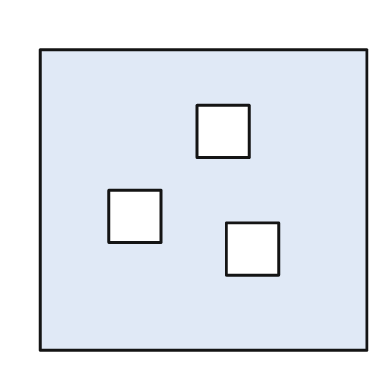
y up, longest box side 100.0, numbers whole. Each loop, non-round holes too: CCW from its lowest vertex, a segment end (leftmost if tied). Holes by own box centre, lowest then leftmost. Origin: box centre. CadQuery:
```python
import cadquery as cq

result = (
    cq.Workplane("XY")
    .moveTo(-50.0, -46.0)
    .lineTo(50.0, -46.0)
    .lineTo(50.0, 46.0)
    .lineTo(-50.0, 46.0)
    .close()
    .moveTo(7.0, -23.0)
    .lineTo(23.0, -23.0)
    .lineTo(23.0, -7.0)
    .lineTo(7.0, -7.0)
    .close()
    .moveTo(-29.0, -13.0)
    .lineTo(-13.0, -13.0)
    .lineTo(-13.0, 3.0)
    .lineTo(-29.0, 3.0)
    .close()
    .moveTo(-2.0, 13.0)
    .lineTo(14.0, 13.0)
    .lineTo(14.0, 29.0)
    .lineTo(-2.0, 29.0)
    .close()
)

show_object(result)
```